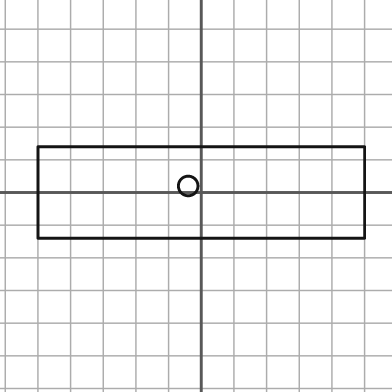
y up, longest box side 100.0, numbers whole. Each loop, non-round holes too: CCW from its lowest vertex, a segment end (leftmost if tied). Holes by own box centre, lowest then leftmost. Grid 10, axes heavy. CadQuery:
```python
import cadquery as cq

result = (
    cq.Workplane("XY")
    .moveTo(-50.0, -14.0)
    .lineTo(50.0, -14.0)
    .lineTo(50.0, 14.0)
    .lineTo(-50.0, 14.0)
    .close()
    .moveTo(-4.0, 2.0)
    .circle(3.0)
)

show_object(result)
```